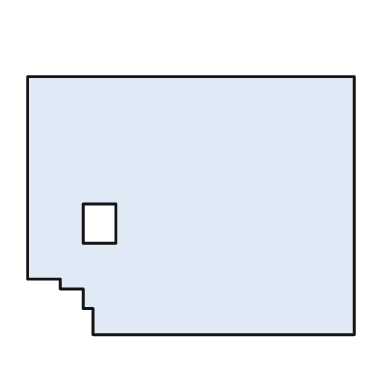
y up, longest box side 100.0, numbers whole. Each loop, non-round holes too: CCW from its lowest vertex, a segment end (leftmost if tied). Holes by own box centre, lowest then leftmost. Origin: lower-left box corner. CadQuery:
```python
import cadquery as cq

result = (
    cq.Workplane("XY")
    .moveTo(20.0, 0.0)
    .lineTo(100.0, 0.0)
    .lineTo(100.0, 79.0)
    .lineTo(0.0, 79.0)
    .lineTo(0.0, 17.0)
    .lineTo(10.0, 17.0)
    .lineTo(10.0, 14.0)
    .lineTo(17.0, 14.0)
    .lineTo(17.0, 8.0)
    .lineTo(20.0, 8.0)
    .close()
    .moveTo(17.0, 28.0)
    .lineTo(27.0, 28.0)
    .lineTo(27.0, 40.0)
    .lineTo(17.0, 40.0)
    .close()
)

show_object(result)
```